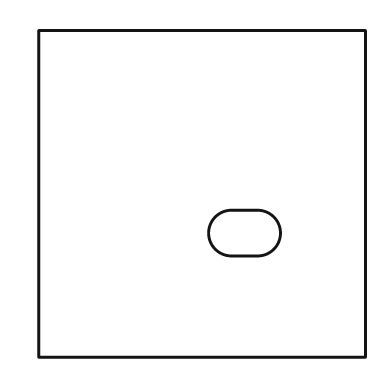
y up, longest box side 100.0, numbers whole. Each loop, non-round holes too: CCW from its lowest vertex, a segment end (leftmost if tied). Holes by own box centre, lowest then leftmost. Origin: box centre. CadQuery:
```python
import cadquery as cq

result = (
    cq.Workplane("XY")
    .moveTo(-50.0, -50.0)
    .lineTo(50.0, -50.0)
    .lineTo(50.0, 50.0)
    .lineTo(-50.0, 50.0)
    .close()
    .moveTo(9.0, -19.0)
    .lineTo(17.0, -19.0)
    .threePointArc((24.0, -12.0), (17.0, -5.0))
    .lineTo(9.0, -5.0)
    .threePointArc((2.0, -12.0), (9.0, -19.0))
    .close()
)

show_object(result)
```